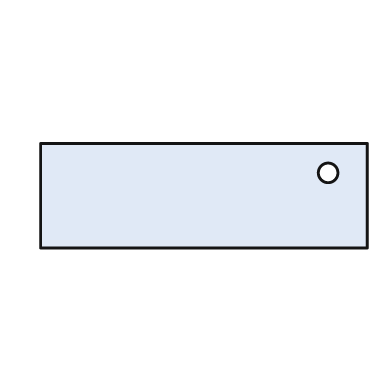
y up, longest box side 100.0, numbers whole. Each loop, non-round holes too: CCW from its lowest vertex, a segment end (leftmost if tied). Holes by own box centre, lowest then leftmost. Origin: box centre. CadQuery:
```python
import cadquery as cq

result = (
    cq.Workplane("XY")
    .moveTo(-50.0, -16.0)
    .lineTo(50.0, -16.0)
    .lineTo(50.0, 16.0)
    .lineTo(-50.0, 16.0)
    .close()
    .moveTo(38.0, 7.0)
    .circle(3.0)
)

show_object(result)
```